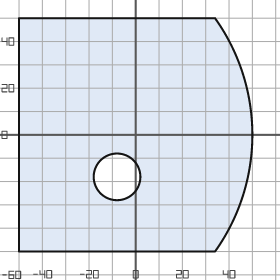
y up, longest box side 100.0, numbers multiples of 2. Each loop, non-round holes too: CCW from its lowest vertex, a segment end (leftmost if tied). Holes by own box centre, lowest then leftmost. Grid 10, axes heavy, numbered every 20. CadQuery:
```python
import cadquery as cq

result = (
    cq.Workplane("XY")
    .moveTo(-50.0, -50.0)
    .lineTo(34.0, -50.0)
    .threePointArc((50.0, 0.0), (34.0, 50.0))
    .lineTo(-50.0, 50.0)
    .close()
    .moveTo(-8.0, -18.0)
    .circle(10.0)
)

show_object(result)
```